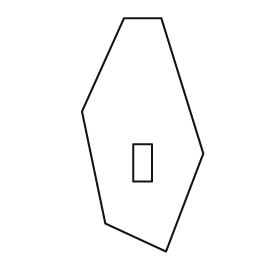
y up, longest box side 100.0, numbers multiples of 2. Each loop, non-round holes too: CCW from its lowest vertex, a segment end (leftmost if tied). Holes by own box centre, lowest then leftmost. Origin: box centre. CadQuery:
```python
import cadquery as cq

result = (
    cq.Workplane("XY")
    .moveTo(10.0, -50.0)
    .lineTo(26.0, -8.0)
    .lineTo(8.0, 50.0)
    .lineTo(-8.0, 50.0)
    .lineTo(-26.0, 10.0)
    .lineTo(-16.0, -38.0)
    .close()
    .moveTo(-4.0, -20.0)
    .lineTo(4.0, -20.0)
    .lineTo(4.0, -4.0)
    .lineTo(-4.0, -4.0)
    .close()
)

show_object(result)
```